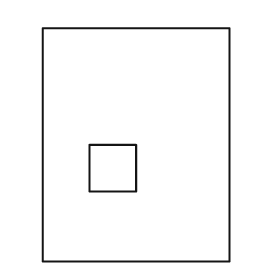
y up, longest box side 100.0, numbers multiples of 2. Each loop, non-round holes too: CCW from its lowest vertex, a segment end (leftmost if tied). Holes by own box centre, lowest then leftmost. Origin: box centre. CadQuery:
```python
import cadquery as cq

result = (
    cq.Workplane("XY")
    .moveTo(-40.0, -50.0)
    .lineTo(40.0, -50.0)
    .lineTo(40.0, 50.0)
    .lineTo(-40.0, 50.0)
    .close()
    .moveTo(-20.0, -20.0)
    .lineTo(0.0, -20.0)
    .lineTo(0.0, 0.0)
    .lineTo(-20.0, 0.0)
    .close()
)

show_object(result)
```